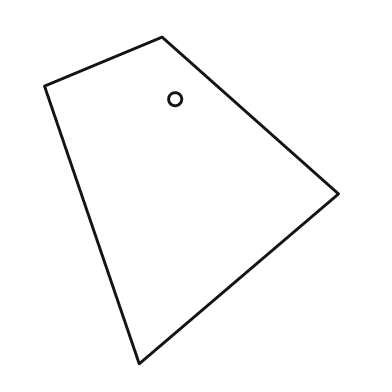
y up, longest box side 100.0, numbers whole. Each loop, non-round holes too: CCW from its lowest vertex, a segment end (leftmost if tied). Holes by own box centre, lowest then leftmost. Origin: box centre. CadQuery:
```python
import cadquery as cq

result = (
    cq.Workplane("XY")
    .moveTo(-16.0, -50.0)
    .lineTo(45.0, 2.0)
    .lineTo(-9.0, 50.0)
    .lineTo(-45.0, 35.0)
    .close()
    .moveTo(-5.0, 31.0)
    .circle(2.0)
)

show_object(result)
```